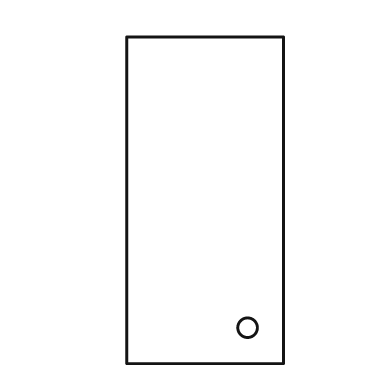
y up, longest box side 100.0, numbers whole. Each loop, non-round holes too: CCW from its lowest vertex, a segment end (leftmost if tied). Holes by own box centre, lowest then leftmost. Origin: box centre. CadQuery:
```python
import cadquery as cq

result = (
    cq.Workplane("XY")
    .moveTo(-24.0, -50.0)
    .lineTo(24.0, -50.0)
    .lineTo(24.0, 50.0)
    .lineTo(-24.0, 50.0)
    .close()
    .moveTo(13.0, -39.0)
    .circle(3.0)
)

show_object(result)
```